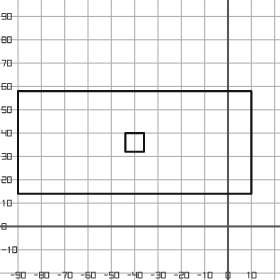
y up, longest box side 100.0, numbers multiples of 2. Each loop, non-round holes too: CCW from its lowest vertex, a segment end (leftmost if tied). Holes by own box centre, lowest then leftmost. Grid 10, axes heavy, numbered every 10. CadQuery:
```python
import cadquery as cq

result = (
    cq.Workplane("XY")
    .moveTo(-90.0, 14.0)
    .lineTo(10.0, 14.0)
    .lineTo(10.0, 58.0)
    .lineTo(-90.0, 58.0)
    .close()
    .moveTo(-44.0, 32.0)
    .lineTo(-36.0, 32.0)
    .lineTo(-36.0, 40.0)
    .lineTo(-44.0, 40.0)
    .close()
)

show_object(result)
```